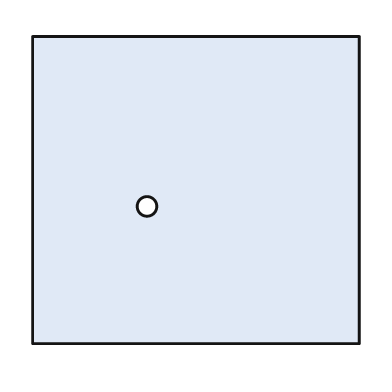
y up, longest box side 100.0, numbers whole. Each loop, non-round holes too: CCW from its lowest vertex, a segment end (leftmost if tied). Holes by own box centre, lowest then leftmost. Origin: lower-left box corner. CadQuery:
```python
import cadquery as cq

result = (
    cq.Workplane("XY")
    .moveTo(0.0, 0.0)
    .lineTo(100.0, 0.0)
    .lineTo(100.0, 94.0)
    .lineTo(0.0, 94.0)
    .close()
    .moveTo(35.0, 42.0)
    .circle(3.0)
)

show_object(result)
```